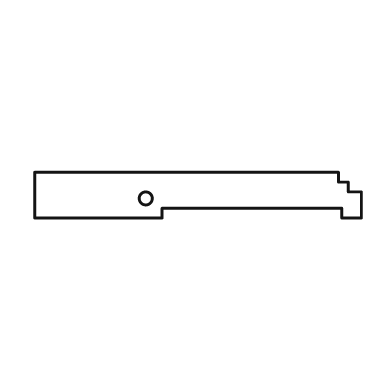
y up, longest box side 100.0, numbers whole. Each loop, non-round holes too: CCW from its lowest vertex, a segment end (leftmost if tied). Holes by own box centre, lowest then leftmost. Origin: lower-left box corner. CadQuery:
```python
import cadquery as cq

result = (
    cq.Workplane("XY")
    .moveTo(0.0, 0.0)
    .lineTo(39.0, 0.0)
    .lineTo(39.0, 3.0)
    .lineTo(94.0, 3.0)
    .lineTo(94.0, 0.0)
    .lineTo(100.0, 0.0)
    .lineTo(100.0, 8.0)
    .lineTo(96.0, 8.0)
    .lineTo(96.0, 11.0)
    .lineTo(93.0, 11.0)
    .lineTo(93.0, 14.0)
    .lineTo(0.0, 14.0)
    .close()
    .moveTo(34.0, 6.0)
    .circle(2.0)
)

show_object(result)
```